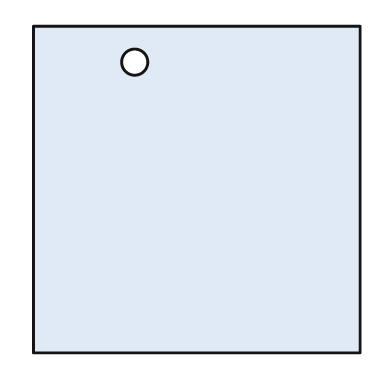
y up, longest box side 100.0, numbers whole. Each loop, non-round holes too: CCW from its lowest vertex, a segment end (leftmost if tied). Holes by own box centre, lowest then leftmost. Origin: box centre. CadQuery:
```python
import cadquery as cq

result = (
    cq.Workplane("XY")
    .moveTo(-50.0, -50.0)
    .lineTo(50.0, -50.0)
    .lineTo(50.0, 50.0)
    .lineTo(-50.0, 50.0)
    .close()
    .moveTo(-19.0, 39.0)
    .circle(4.0)
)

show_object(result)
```